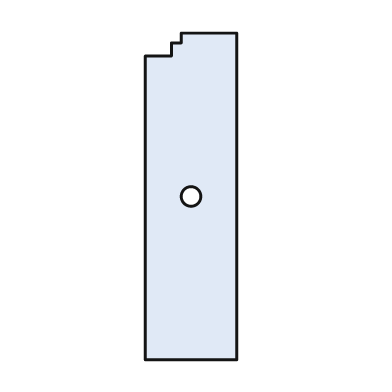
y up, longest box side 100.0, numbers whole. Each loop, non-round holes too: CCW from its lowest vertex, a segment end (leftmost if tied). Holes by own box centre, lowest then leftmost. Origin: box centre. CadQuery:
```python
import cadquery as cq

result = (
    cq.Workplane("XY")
    .moveTo(-14.0, -50.0)
    .lineTo(14.0, -50.0)
    .lineTo(14.0, 50.0)
    .lineTo(-3.0, 50.0)
    .lineTo(-3.0, 47.0)
    .lineTo(-6.0, 47.0)
    .lineTo(-6.0, 43.0)
    .lineTo(-14.0, 43.0)
    .close()
    .moveTo(0.0, 0.0)
    .circle(3.0)
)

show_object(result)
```